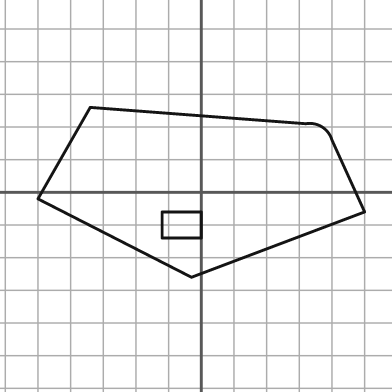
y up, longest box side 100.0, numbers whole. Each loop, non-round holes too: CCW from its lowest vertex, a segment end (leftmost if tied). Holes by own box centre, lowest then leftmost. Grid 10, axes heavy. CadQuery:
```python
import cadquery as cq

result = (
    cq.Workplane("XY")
    .moveTo(-3.0, -26.0)
    .lineTo(50.0, -6.0)
    .lineTo(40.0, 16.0)
    .threePointArc((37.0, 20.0), (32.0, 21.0))
    .lineTo(-34.0, 26.0)
    .lineTo(-50.0, -2.0)
    .close()
    .moveTo(-12.0, -14.0)
    .lineTo(0.0, -14.0)
    .lineTo(0.0, -6.0)
    .lineTo(-12.0, -6.0)
    .close()
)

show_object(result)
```